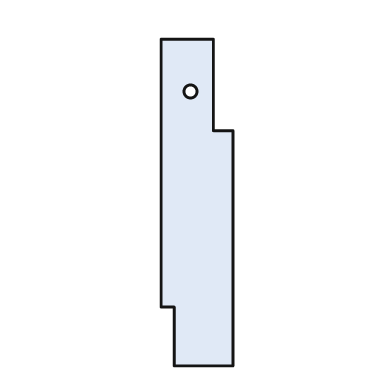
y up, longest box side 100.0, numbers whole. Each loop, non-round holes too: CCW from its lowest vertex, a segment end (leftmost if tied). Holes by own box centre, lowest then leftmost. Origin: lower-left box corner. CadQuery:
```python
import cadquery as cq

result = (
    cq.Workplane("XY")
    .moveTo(4.0, 0.0)
    .lineTo(22.0, 0.0)
    .lineTo(22.0, 72.0)
    .lineTo(16.0, 72.0)
    .lineTo(16.0, 100.0)
    .lineTo(0.0, 100.0)
    .lineTo(0.0, 18.0)
    .lineTo(4.0, 18.0)
    .close()
    .moveTo(9.0, 84.0)
    .circle(2.0)
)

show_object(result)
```